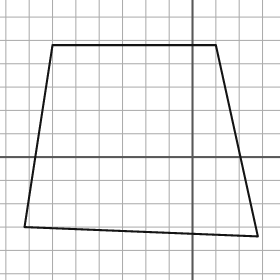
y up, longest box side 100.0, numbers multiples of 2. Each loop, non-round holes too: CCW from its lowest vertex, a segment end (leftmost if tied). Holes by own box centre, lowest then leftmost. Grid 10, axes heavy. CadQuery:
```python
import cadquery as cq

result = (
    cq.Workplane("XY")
    .moveTo(28.0, -34.0)
    .lineTo(10.0, 48.0)
    .lineTo(-60.0, 48.0)
    .lineTo(-72.0, -30.0)
    .close()
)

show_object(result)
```